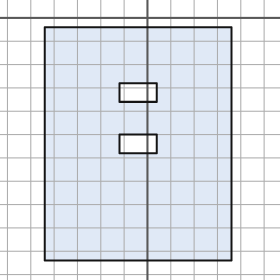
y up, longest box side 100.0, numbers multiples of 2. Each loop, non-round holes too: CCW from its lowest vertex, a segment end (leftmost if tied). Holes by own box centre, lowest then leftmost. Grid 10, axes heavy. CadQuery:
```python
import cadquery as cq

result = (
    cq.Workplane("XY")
    .moveTo(-44.0, -104.0)
    .lineTo(36.0, -104.0)
    .lineTo(36.0, -4.0)
    .lineTo(-44.0, -4.0)
    .close()
    .moveTo(-12.0, -58.0)
    .lineTo(4.0, -58.0)
    .lineTo(4.0, -50.0)
    .lineTo(-12.0, -50.0)
    .close()
    .moveTo(-12.0, -36.0)
    .lineTo(4.0, -36.0)
    .lineTo(4.0, -28.0)
    .lineTo(-12.0, -28.0)
    .close()
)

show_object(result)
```